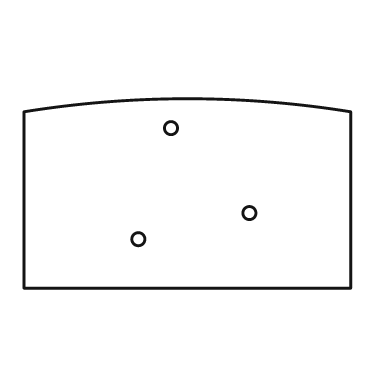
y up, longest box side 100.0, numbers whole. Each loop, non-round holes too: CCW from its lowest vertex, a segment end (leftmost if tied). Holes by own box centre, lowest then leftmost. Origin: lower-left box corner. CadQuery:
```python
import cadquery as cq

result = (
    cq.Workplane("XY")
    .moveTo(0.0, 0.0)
    .lineTo(100.0, 0.0)
    .lineTo(100.0, 54.0)
    .threePointArc((50.0, 58.0), (0.0, 54.0))
    .close()
    .moveTo(35.0, 15.0)
    .circle(2.0)
    .moveTo(69.0, 23.0)
    .circle(2.0)
    .moveTo(45.0, 49.0)
    .circle(2.0)
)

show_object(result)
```